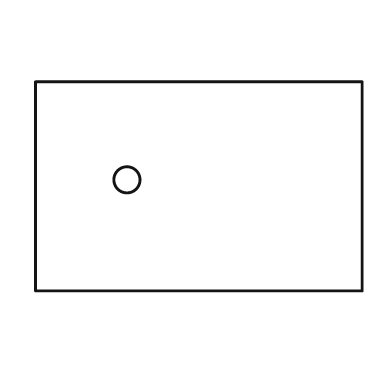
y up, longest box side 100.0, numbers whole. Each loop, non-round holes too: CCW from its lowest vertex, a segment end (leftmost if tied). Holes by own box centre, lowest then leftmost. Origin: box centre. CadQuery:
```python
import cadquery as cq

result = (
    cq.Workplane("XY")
    .moveTo(-50.0, -32.0)
    .lineTo(50.0, -32.0)
    .lineTo(50.0, 32.0)
    .lineTo(-50.0, 32.0)
    .close()
    .moveTo(-22.0, 2.0)
    .circle(4.0)
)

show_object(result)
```